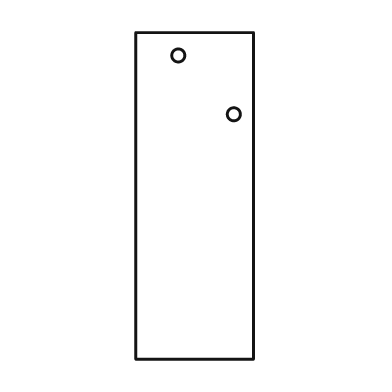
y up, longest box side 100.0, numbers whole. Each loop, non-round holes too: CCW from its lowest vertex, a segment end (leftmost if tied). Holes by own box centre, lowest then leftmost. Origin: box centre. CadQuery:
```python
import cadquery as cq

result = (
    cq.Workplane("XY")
    .moveTo(-18.0, -50.0)
    .lineTo(18.0, -50.0)
    .lineTo(18.0, 50.0)
    .lineTo(-18.0, 50.0)
    .close()
    .moveTo(12.0, 25.0)
    .circle(2.0)
    .moveTo(-5.0, 43.0)
    .circle(2.0)
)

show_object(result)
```